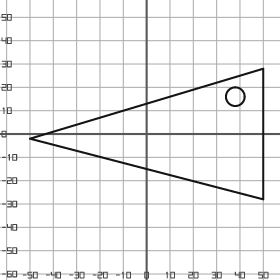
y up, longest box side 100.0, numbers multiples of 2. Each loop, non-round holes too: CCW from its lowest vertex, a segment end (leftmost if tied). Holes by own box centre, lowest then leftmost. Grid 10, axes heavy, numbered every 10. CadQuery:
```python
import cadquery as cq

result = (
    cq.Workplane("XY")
    .moveTo(50.0, -28.0)
    .lineTo(50.0, 28.0)
    .lineTo(-50.0, -2.0)
    .close()
    .moveTo(38.0, 16.0)
    .circle(4.0)
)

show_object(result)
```